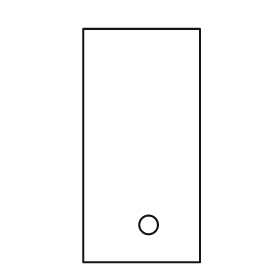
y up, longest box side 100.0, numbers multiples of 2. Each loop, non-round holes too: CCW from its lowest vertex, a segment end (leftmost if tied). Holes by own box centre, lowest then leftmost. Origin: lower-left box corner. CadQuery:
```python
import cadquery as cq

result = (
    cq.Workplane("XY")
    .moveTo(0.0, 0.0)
    .lineTo(50.0, 0.0)
    .lineTo(50.0, 100.0)
    .lineTo(0.0, 100.0)
    .close()
    .moveTo(28.0, 16.0)
    .circle(4.0)
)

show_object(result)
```